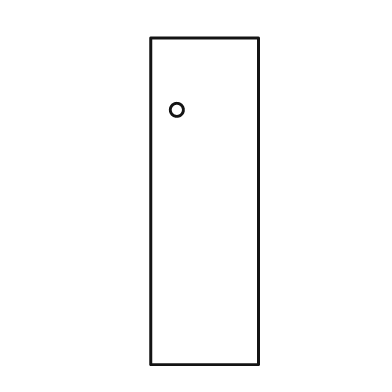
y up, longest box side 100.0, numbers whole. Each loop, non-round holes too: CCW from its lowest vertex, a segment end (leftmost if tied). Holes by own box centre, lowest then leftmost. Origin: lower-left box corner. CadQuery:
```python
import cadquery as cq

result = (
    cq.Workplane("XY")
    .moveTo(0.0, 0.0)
    .lineTo(33.0, 0.0)
    .lineTo(33.0, 100.0)
    .lineTo(0.0, 100.0)
    .close()
    .moveTo(8.0, 78.0)
    .circle(2.0)
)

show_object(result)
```